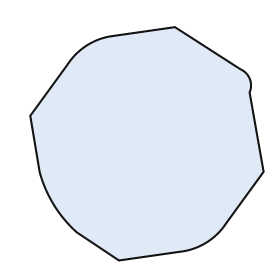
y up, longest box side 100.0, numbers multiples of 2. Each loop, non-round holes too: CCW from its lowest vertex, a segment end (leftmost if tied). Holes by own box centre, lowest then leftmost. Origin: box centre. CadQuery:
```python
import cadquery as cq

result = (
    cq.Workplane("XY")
    .moveTo(-12.0, -50.0)
    .lineTo(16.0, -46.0)
    .threePointArc((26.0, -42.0), (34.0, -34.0))
    .lineTo(50.0, -12.0)
    .lineTo(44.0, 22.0)
    .threePointArc((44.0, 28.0), (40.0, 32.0))
    .lineTo(12.0, 50.0)
    .lineTo(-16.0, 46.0)
    .threePointArc((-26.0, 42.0), (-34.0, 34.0))
    .lineTo(-50.0, 12.0)
    .lineTo(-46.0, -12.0)
    .threePointArc((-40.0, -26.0), (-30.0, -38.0))
    .close()
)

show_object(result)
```